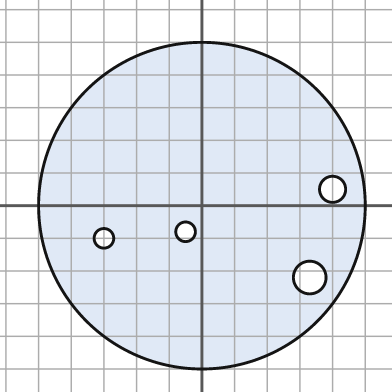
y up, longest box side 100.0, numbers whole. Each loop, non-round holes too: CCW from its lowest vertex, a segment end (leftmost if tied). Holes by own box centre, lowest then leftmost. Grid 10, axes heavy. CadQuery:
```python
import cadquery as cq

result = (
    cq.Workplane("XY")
    .moveTo(0.0, 0.0)
    .circle(50.0)
    .moveTo(33.0, -22.0)
    .circle(5.0)
    .moveTo(-30.0, -10.0)
    .circle(3.0)
    .moveTo(-5.0, -8.0)
    .circle(3.0)
    .moveTo(40.0, 5.0)
    .circle(4.0)
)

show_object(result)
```